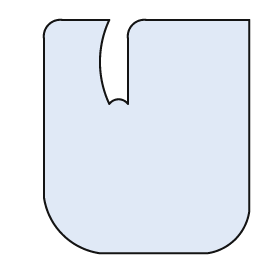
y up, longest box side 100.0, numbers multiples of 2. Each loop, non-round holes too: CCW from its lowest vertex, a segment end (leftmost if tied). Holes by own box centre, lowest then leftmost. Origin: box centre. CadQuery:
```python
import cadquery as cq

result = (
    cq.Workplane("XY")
    .moveTo(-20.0, -50.0)
    .lineTo(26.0, -50.0)
    .threePointArc((38.0, -44.0), (44.0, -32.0))
    .lineTo(44.0, 50.0)
    .lineTo(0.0, 50.0)
    .threePointArc((-6.0, 48.0), (-8.0, 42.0))
    .lineTo(-8.0, 14.0)
    .threePointArc((-12.0, 16.0), (-16.0, 14.0))
    .threePointArc((-20.0, 32.0), (-16.0, 50.0))
    .lineTo(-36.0, 50.0)
    .threePointArc((-42.0, 48.0), (-44.0, 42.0))
    .lineTo(-44.0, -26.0)
    .threePointArc((-36.0, -42.0), (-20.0, -50.0))
    .close()
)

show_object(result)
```